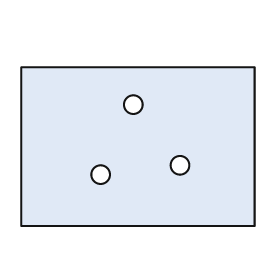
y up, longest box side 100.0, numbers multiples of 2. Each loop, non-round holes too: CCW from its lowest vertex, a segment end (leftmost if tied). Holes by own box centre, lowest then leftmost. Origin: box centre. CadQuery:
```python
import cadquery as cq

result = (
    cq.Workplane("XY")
    .moveTo(-50.0, -34.0)
    .lineTo(50.0, -34.0)
    .lineTo(50.0, 34.0)
    .lineTo(-50.0, 34.0)
    .close()
    .moveTo(-16.0, -12.0)
    .circle(4.0)
    .moveTo(18.0, -8.0)
    .circle(4.0)
    .moveTo(-2.0, 18.0)
    .circle(4.0)
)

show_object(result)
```